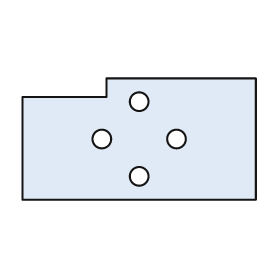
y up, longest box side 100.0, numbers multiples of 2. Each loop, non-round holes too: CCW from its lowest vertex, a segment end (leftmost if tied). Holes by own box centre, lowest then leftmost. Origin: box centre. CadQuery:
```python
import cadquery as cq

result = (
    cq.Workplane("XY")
    .moveTo(-50.0, -26.0)
    .lineTo(50.0, -26.0)
    .lineTo(50.0, 26.0)
    .lineTo(-14.0, 26.0)
    .lineTo(-14.0, 18.0)
    .lineTo(-50.0, 18.0)
    .close()
    .moveTo(0.0, -16.0)
    .circle(4.0)
    .moveTo(-16.0, 0.0)
    .circle(4.0)
    .moveTo(16.0, 0.0)
    .circle(4.0)
    .moveTo(0.0, 16.0)
    .circle(4.0)
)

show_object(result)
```